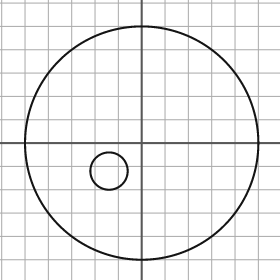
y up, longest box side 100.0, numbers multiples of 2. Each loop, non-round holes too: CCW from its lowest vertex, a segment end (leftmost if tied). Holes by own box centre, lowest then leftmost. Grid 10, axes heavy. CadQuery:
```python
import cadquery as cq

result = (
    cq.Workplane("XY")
    .moveTo(0.0, 0.0)
    .circle(50.0)
    .moveTo(-14.0, -12.0)
    .circle(8.0)
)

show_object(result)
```